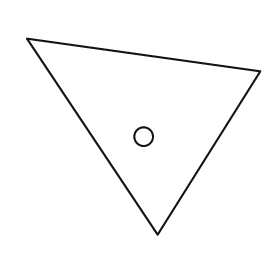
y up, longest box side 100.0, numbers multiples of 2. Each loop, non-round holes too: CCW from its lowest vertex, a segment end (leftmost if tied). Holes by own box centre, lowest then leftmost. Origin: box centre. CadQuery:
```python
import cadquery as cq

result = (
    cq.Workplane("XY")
    .moveTo(6.0, -42.0)
    .lineTo(50.0, 28.0)
    .lineTo(-50.0, 42.0)
    .close()
    .moveTo(0.0, 0.0)
    .circle(4.0)
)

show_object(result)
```